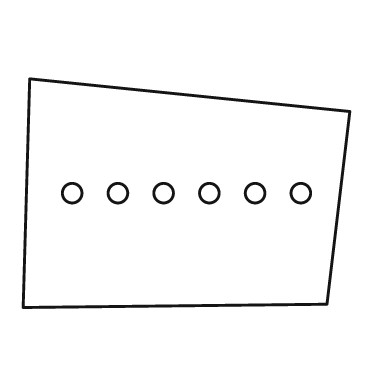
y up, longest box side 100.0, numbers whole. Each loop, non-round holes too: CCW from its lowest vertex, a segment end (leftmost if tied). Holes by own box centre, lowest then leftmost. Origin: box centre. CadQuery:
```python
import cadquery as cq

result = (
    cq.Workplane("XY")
    .moveTo(-50.0, -35.0)
    .lineTo(43.0, -34.0)
    .lineTo(50.0, 25.0)
    .lineTo(-48.0, 35.0)
    .close()
    .moveTo(-35.0, 0.0)
    .circle(3.0)
    .moveTo(-21.0, 0.0)
    .circle(3.0)
    .moveTo(-7.0, 0.0)
    .circle(3.0)
    .moveTo(7.0, 0.0)
    .circle(3.0)
    .moveTo(21.0, 0.0)
    .circle(3.0)
    .moveTo(35.0, 0.0)
    .circle(3.0)
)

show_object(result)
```